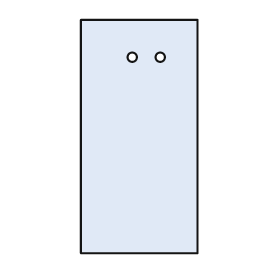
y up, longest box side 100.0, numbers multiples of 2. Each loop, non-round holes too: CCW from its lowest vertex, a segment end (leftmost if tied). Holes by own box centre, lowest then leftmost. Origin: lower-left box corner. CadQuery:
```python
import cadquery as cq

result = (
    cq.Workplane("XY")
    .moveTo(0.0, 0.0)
    .lineTo(50.0, 0.0)
    .lineTo(50.0, 100.0)
    .lineTo(0.0, 100.0)
    .close()
    .moveTo(22.0, 84.0)
    .circle(2.0)
    .moveTo(34.0, 84.0)
    .circle(2.0)
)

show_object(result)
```